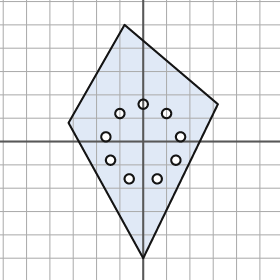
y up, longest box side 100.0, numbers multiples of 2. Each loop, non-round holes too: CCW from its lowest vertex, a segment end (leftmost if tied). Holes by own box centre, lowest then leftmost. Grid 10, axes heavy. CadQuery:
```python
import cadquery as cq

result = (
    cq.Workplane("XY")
    .moveTo(0.0, -50.0)
    .lineTo(32.0, 16.0)
    .lineTo(-8.0, 50.0)
    .lineTo(-32.0, 8.0)
    .close()
    .moveTo(-6.0, -16.0)
    .circle(2.0)
    .moveTo(6.0, -16.0)
    .circle(2.0)
    .moveTo(-14.0, -8.0)
    .circle(2.0)
    .moveTo(14.0, -8.0)
    .circle(2.0)
    .moveTo(-16.0, 2.0)
    .circle(2.0)
    .moveTo(16.0, 2.0)
    .circle(2.0)
    .moveTo(-10.0, 12.0)
    .circle(2.0)
    .moveTo(10.0, 12.0)
    .circle(2.0)
    .moveTo(0.0, 16.0)
    .circle(2.0)
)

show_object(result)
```